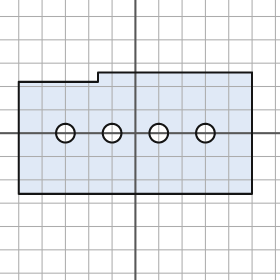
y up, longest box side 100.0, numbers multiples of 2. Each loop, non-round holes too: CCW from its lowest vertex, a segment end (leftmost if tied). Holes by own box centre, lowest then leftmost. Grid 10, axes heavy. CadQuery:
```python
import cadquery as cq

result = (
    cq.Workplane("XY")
    .moveTo(-50.0, -26.0)
    .lineTo(50.0, -26.0)
    .lineTo(50.0, 26.0)
    .lineTo(-16.0, 26.0)
    .lineTo(-16.0, 22.0)
    .lineTo(-50.0, 22.0)
    .close()
    .moveTo(-30.0, 0.0)
    .circle(4.0)
    .moveTo(-10.0, 0.0)
    .circle(4.0)
    .moveTo(10.0, 0.0)
    .circle(4.0)
    .moveTo(30.0, 0.0)
    .circle(4.0)
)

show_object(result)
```